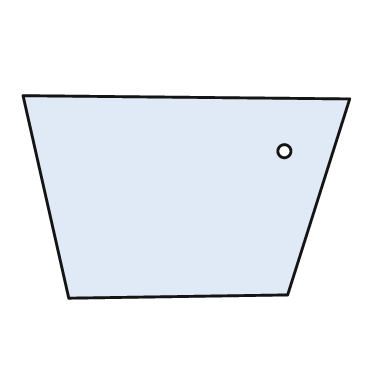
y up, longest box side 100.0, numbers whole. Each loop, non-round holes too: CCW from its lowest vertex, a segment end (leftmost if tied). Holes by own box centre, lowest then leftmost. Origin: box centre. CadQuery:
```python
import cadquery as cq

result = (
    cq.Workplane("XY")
    .moveTo(-36.0, -31.0)
    .lineTo(31.0, -30.0)
    .lineTo(50.0, 30.0)
    .lineTo(-50.0, 31.0)
    .close()
    .moveTo(30.0, 14.0)
    .circle(2.0)
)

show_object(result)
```